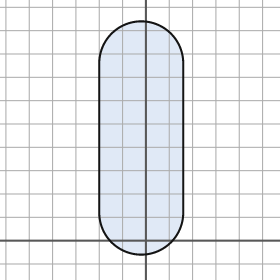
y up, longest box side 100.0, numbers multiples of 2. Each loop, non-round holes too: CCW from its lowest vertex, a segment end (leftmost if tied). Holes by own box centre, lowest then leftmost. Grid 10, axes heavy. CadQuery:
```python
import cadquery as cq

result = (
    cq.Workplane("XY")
    .moveTo(-20.0, 12.0)
    .threePointArc((-2.0, -6.0), (16.0, 12.0))
    .lineTo(16.0, 76.0)
    .threePointArc((-2.0, 94.0), (-20.0, 76.0))
    .close()
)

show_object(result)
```